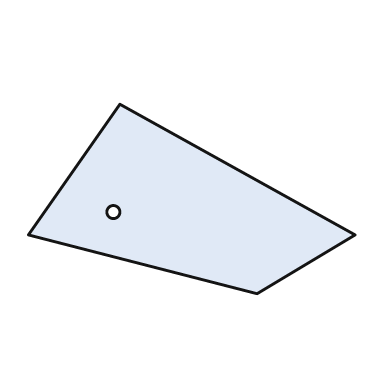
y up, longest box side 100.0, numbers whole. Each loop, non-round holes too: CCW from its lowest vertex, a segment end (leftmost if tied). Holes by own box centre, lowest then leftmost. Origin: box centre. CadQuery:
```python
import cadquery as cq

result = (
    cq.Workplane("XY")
    .moveTo(20.0, -29.0)
    .lineTo(50.0, -11.0)
    .lineTo(-22.0, 29.0)
    .lineTo(-50.0, -11.0)
    .close()
    .moveTo(-24.0, -4.0)
    .circle(2.0)
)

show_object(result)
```